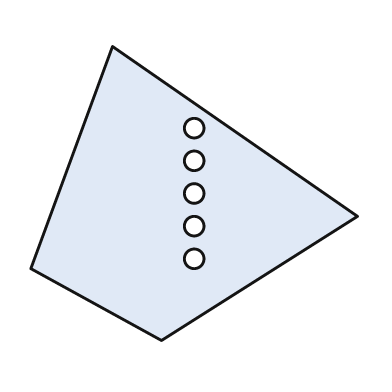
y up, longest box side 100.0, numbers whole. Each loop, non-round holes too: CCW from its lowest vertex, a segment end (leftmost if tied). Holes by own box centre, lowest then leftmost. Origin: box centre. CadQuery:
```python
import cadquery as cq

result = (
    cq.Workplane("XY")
    .moveTo(-10.0, -45.0)
    .lineTo(50.0, -7.0)
    .lineTo(-25.0, 45.0)
    .lineTo(-50.0, -23.0)
    .close()
    .moveTo(0.0, -20.0)
    .circle(3.0)
    .moveTo(0.0, -10.0)
    .circle(3.0)
    .moveTo(0.0, 0.0)
    .circle(3.0)
    .moveTo(0.0, 10.0)
    .circle(3.0)
    .moveTo(0.0, 20.0)
    .circle(3.0)
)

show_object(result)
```